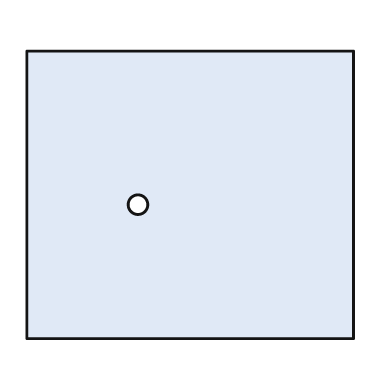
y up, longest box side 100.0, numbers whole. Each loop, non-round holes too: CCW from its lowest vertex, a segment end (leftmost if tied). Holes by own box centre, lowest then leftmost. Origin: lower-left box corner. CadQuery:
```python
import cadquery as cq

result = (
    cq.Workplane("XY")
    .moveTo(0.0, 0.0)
    .lineTo(100.0, 0.0)
    .lineTo(100.0, 88.0)
    .lineTo(0.0, 88.0)
    .close()
    .moveTo(34.0, 41.0)
    .circle(3.0)
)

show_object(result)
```